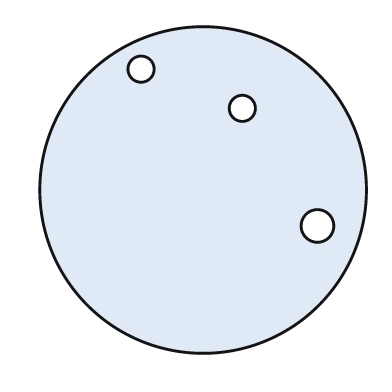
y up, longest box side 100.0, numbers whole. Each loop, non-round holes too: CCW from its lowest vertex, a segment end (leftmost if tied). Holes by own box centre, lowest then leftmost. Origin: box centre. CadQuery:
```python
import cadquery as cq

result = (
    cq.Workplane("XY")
    .moveTo(0.0, 0.0)
    .circle(50.0)
    .moveTo(35.0, -11.0)
    .circle(5.0)
    .moveTo(12.0, 25.0)
    .circle(4.0)
    .moveTo(-19.0, 37.0)
    .circle(4.0)
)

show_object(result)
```